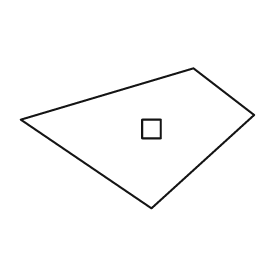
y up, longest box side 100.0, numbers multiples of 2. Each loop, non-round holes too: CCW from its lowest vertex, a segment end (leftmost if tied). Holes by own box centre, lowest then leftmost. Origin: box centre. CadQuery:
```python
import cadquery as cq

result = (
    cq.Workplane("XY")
    .moveTo(6.0, -30.0)
    .lineTo(50.0, 10.0)
    .lineTo(24.0, 30.0)
    .lineTo(-50.0, 8.0)
    .close()
    .moveTo(2.0, 0.0)
    .lineTo(10.0, 0.0)
    .lineTo(10.0, 8.0)
    .lineTo(2.0, 8.0)
    .close()
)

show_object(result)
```